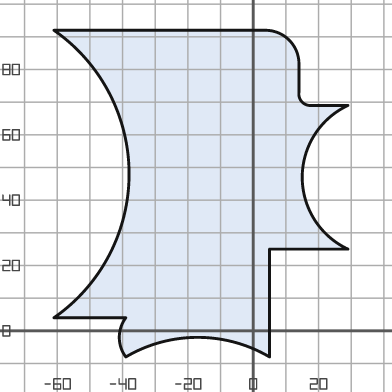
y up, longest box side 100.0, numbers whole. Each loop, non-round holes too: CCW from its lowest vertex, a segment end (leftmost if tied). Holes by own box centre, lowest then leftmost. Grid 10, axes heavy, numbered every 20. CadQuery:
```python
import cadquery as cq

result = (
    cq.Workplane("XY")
    .moveTo(-39.0, -8.0)
    .threePointArc((-17.0, -2.0), (5.0, -8.0))
    .lineTo(5.0, 25.0)
    .lineTo(29.0, 25.0)
    .threePointArc((15.0, 47.0), (29.0, 69.0))
    .lineTo(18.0, 69.0)
    .threePointArc((15.0, 70.0), (14.0, 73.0))
    .lineTo(14.0, 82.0)
    .threePointArc((11.0, 89.0), (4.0, 92.0))
    .lineTo(-61.0, 92.0)
    .threePointArc((-38.0, 48.0), (-61.0, 4.0))
    .lineTo(-39.0, 4.0)
    .threePointArc((-41.0, -2.0), (-39.0, -8.0))
    .close()
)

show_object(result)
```